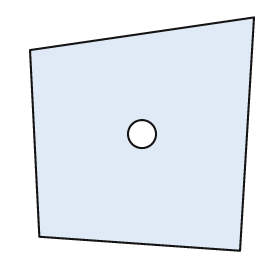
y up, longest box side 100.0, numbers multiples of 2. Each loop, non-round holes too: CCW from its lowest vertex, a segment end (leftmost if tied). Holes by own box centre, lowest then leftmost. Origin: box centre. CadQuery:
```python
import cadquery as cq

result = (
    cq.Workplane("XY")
    .moveTo(42.0, -50.0)
    .lineTo(48.0, 50.0)
    .lineTo(-48.0, 36.0)
    .lineTo(-44.0, -44.0)
    .close()
    .moveTo(0.0, 0.0)
    .circle(6.0)
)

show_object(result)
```